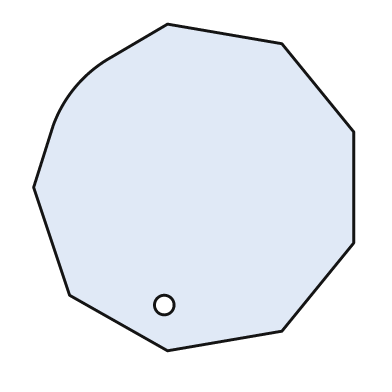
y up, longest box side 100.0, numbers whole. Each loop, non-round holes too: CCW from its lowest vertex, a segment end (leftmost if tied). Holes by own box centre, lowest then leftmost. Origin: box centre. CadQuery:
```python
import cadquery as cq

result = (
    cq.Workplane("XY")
    .moveTo(-8.0, -50.0)
    .lineTo(27.0, -44.0)
    .lineTo(49.0, -17.0)
    .lineTo(49.0, 17.0)
    .lineTo(27.0, 44.0)
    .lineTo(-8.0, 50.0)
    .lineTo(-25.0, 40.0)
    .threePointArc((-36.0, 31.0), (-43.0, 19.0))
    .lineTo(-49.0, 0.0)
    .lineTo(-38.0, -33.0)
    .close()
    .moveTo(-9.0, -36.0)
    .circle(3.0)
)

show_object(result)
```